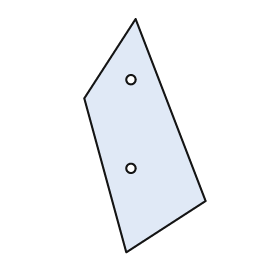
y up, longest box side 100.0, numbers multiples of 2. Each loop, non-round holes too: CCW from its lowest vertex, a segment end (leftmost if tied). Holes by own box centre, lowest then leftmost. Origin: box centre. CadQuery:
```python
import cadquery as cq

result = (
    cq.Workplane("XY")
    .moveTo(-8.0, -50.0)
    .lineTo(26.0, -28.0)
    .lineTo(-4.0, 50.0)
    .lineTo(-26.0, 16.0)
    .close()
    .moveTo(-6.0, -14.0)
    .circle(2.0)
    .moveTo(-6.0, 24.0)
    .circle(2.0)
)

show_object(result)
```